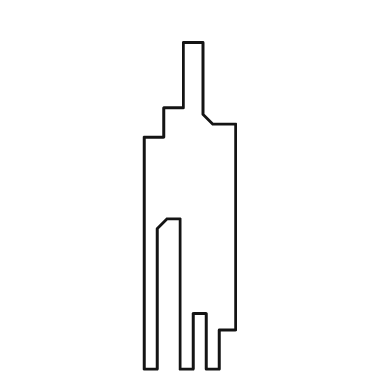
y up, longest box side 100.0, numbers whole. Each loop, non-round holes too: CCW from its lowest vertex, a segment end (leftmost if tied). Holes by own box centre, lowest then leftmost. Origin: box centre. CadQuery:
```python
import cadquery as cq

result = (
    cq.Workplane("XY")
    .moveTo(-14.0, -50.0)
    .lineTo(-10.0, -50.0)
    .lineTo(-10.0, -7.0)
    .lineTo(-7.0, -4.0)
    .lineTo(-3.0, -4.0)
    .lineTo(-3.0, -50.0)
    .lineTo(1.0, -50.0)
    .lineTo(1.0, -33.0)
    .lineTo(5.0, -33.0)
    .lineTo(5.0, -50.0)
    .lineTo(9.0, -50.0)
    .lineTo(9.0, -38.0)
    .lineTo(14.0, -38.0)
    .lineTo(14.0, 25.0)
    .lineTo(7.0, 25.0)
    .lineTo(4.0, 28.0)
    .lineTo(4.0, 50.0)
    .lineTo(-2.0, 50.0)
    .lineTo(-2.0, 30.0)
    .lineTo(-8.0, 30.0)
    .lineTo(-8.0, 21.0)
    .lineTo(-14.0, 21.0)
    .close()
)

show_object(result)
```